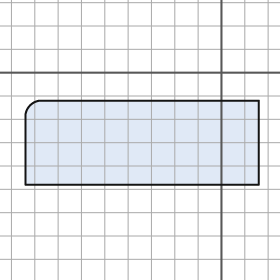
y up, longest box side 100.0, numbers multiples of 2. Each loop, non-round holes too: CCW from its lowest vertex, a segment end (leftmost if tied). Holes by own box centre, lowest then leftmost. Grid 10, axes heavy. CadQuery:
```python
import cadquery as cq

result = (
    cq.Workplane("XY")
    .moveTo(-84.0, -48.0)
    .lineTo(16.0, -48.0)
    .lineTo(16.0, -12.0)
    .lineTo(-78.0, -12.0)
    .threePointArc((-82.0, -14.0), (-84.0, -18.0))
    .close()
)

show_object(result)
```